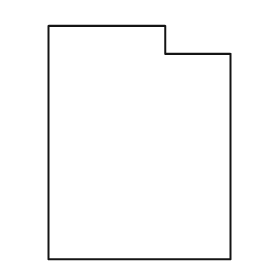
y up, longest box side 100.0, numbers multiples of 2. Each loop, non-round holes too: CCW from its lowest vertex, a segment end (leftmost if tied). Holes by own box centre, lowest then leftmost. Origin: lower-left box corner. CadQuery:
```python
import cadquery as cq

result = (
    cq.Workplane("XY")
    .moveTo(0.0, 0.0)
    .lineTo(78.0, 0.0)
    .lineTo(78.0, 88.0)
    .lineTo(50.0, 88.0)
    .lineTo(50.0, 100.0)
    .lineTo(0.0, 100.0)
    .close()
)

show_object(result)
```